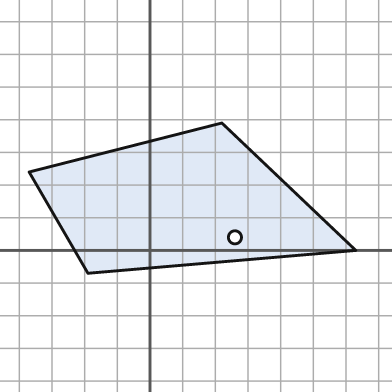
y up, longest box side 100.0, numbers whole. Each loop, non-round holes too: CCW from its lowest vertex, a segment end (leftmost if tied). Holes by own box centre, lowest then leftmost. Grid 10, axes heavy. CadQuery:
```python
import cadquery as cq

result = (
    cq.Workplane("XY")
    .moveTo(-19.0, -7.0)
    .lineTo(63.0, 0.0)
    .lineTo(22.0, 39.0)
    .lineTo(-37.0, 24.0)
    .close()
    .moveTo(26.0, 4.0)
    .circle(2.0)
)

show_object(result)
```